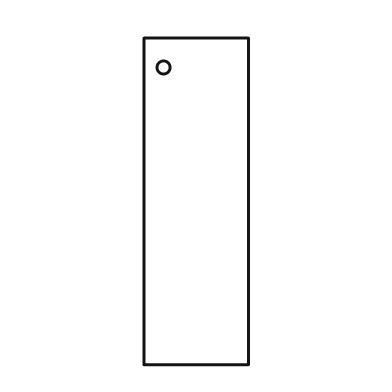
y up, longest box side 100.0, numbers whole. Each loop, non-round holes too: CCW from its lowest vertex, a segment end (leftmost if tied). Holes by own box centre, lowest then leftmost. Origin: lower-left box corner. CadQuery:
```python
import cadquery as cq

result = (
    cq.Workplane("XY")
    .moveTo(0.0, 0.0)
    .lineTo(32.0, 0.0)
    .lineTo(32.0, 100.0)
    .lineTo(0.0, 100.0)
    .close()
    .moveTo(6.0, 91.0)
    .circle(2.0)
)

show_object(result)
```